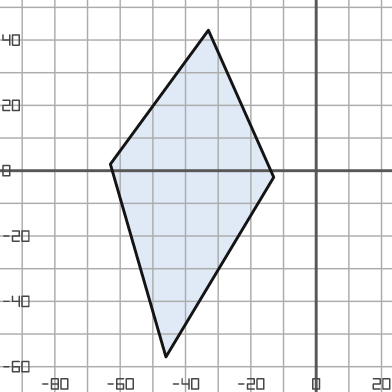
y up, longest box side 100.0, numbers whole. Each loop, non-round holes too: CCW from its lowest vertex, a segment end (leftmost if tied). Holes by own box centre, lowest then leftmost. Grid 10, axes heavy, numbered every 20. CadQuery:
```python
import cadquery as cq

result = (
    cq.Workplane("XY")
    .moveTo(-46.0, -57.0)
    .lineTo(-13.0, -2.0)
    .lineTo(-33.0, 43.0)
    .lineTo(-63.0, 2.0)
    .close()
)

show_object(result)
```